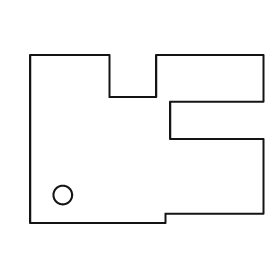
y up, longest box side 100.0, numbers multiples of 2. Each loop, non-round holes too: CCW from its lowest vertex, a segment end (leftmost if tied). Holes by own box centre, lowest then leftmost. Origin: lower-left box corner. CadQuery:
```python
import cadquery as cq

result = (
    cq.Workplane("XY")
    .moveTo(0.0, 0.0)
    .lineTo(58.0, 0.0)
    .lineTo(58.0, 4.0)
    .lineTo(100.0, 4.0)
    .lineTo(100.0, 36.0)
    .lineTo(60.0, 36.0)
    .lineTo(60.0, 52.0)
    .lineTo(100.0, 52.0)
    .lineTo(100.0, 72.0)
    .lineTo(54.0, 72.0)
    .lineTo(54.0, 54.0)
    .lineTo(34.0, 54.0)
    .lineTo(34.0, 72.0)
    .lineTo(0.0, 72.0)
    .close()
    .moveTo(14.0, 12.0)
    .circle(4.0)
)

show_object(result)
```